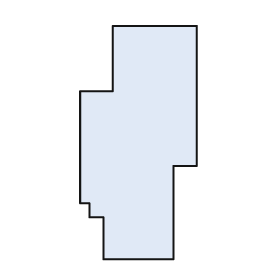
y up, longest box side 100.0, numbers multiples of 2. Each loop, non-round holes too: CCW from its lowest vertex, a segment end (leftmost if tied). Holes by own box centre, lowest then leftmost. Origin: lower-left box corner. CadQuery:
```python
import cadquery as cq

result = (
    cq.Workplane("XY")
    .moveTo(10.0, 0.0)
    .lineTo(40.0, 0.0)
    .lineTo(40.0, 40.0)
    .lineTo(50.0, 40.0)
    .lineTo(50.0, 100.0)
    .lineTo(14.0, 100.0)
    .lineTo(14.0, 72.0)
    .lineTo(0.0, 72.0)
    .lineTo(0.0, 24.0)
    .lineTo(4.0, 24.0)
    .lineTo(4.0, 18.0)
    .lineTo(10.0, 18.0)
    .close()
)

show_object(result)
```